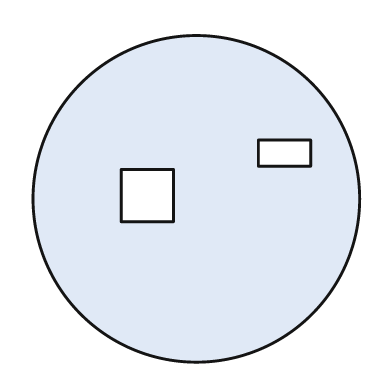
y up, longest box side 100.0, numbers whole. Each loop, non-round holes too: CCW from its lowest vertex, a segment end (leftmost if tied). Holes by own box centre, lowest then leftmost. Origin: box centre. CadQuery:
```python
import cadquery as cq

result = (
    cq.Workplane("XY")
    .moveTo(0.0, 0.0)
    .circle(50.0)
    .moveTo(-23.0, -7.0)
    .lineTo(-7.0, -7.0)
    .lineTo(-7.0, 9.0)
    .lineTo(-23.0, 9.0)
    .close()
    .moveTo(19.0, 10.0)
    .lineTo(35.0, 10.0)
    .lineTo(35.0, 18.0)
    .lineTo(19.0, 18.0)
    .close()
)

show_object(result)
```